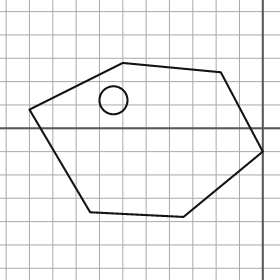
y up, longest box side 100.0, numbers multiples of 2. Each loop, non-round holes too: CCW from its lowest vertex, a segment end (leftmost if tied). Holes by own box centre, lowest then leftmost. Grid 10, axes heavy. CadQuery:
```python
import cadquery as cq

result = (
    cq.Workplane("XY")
    .moveTo(-34.0, -38.0)
    .lineTo(0.0, -10.0)
    .lineTo(-18.0, 24.0)
    .lineTo(-60.0, 28.0)
    .lineTo(-100.0, 8.0)
    .lineTo(-74.0, -36.0)
    .close()
    .moveTo(-64.0, 12.0)
    .circle(6.0)
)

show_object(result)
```